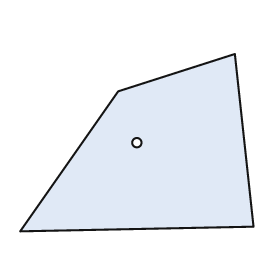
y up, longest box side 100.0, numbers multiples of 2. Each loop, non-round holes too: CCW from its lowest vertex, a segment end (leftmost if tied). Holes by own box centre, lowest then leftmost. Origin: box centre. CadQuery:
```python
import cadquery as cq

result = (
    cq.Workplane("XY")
    .moveTo(-50.0, -38.0)
    .lineTo(50.0, -36.0)
    .lineTo(42.0, 38.0)
    .lineTo(-8.0, 22.0)
    .close()
    .moveTo(0.0, 0.0)
    .circle(2.0)
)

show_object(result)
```